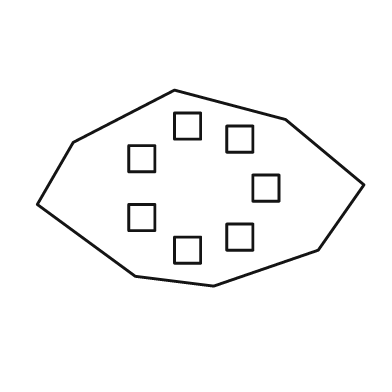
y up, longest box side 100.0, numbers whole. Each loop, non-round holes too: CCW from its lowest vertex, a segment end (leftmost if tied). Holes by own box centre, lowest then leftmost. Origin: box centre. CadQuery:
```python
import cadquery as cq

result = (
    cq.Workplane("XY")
    .moveTo(4.0, -30.0)
    .lineTo(36.0, -19.0)
    .lineTo(50.0, 1.0)
    .lineTo(26.0, 21.0)
    .lineTo(-8.0, 30.0)
    .lineTo(-39.0, 14.0)
    .lineTo(-50.0, -5.0)
    .lineTo(-20.0, -27.0)
    .close()
    .moveTo(-8.0, -23.0)
    .lineTo(0.0, -23.0)
    .lineTo(0.0, -15.0)
    .lineTo(-8.0, -15.0)
    .close()
    .moveTo(8.0, -19.0)
    .lineTo(16.0, -19.0)
    .lineTo(16.0, -11.0)
    .lineTo(8.0, -11.0)
    .close()
    .moveTo(-22.0, -13.0)
    .lineTo(-14.0, -13.0)
    .lineTo(-14.0, -5.0)
    .lineTo(-22.0, -5.0)
    .close()
    .moveTo(16.0, -4.0)
    .lineTo(24.0, -4.0)
    .lineTo(24.0, 4.0)
    .lineTo(16.0, 4.0)
    .close()
    .moveTo(-22.0, 5.0)
    .lineTo(-14.0, 5.0)
    .lineTo(-14.0, 13.0)
    .lineTo(-22.0, 13.0)
    .close()
    .moveTo(8.0, 11.0)
    .lineTo(16.0, 11.0)
    .lineTo(16.0, 19.0)
    .lineTo(8.0, 19.0)
    .close()
    .moveTo(-8.0, 15.0)
    .lineTo(0.0, 15.0)
    .lineTo(0.0, 23.0)
    .lineTo(-8.0, 23.0)
    .close()
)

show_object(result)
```